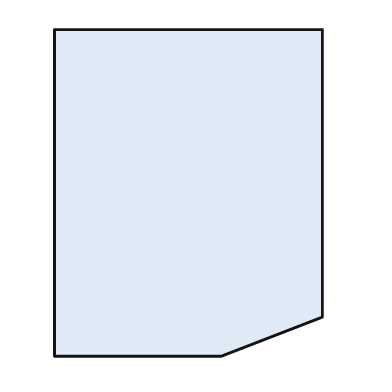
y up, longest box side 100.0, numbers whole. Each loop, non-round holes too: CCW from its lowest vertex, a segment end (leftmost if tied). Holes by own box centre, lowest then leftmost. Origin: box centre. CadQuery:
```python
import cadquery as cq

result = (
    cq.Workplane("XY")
    .moveTo(-41.0, -50.0)
    .lineTo(10.0, -50.0)
    .lineTo(41.0, -38.0)
    .lineTo(41.0, 50.0)
    .lineTo(-41.0, 50.0)
    .close()
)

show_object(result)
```